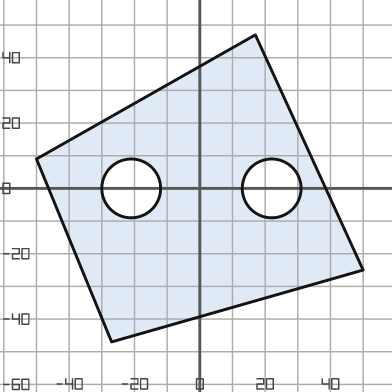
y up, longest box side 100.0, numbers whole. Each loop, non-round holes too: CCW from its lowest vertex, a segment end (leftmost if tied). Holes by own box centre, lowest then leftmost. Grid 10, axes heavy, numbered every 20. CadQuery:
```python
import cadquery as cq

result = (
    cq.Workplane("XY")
    .moveTo(-27.0, -47.0)
    .lineTo(50.0, -25.0)
    .lineTo(17.0, 47.0)
    .lineTo(-50.0, 9.0)
    .close()
    .moveTo(-21.0, 0.0)
    .circle(9.0)
    .moveTo(22.0, 0.0)
    .circle(9.0)
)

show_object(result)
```